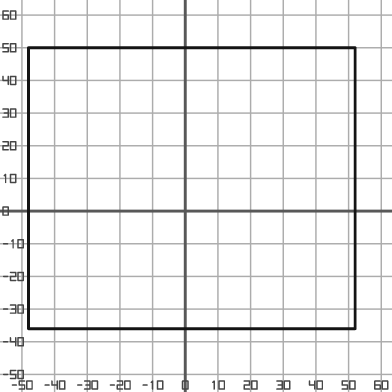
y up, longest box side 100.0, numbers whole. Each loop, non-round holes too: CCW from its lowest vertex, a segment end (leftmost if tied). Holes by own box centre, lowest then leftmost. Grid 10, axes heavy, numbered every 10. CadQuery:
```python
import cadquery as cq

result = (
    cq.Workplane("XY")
    .moveTo(-48.0, -36.0)
    .lineTo(52.0, -36.0)
    .lineTo(52.0, 50.0)
    .lineTo(-48.0, 50.0)
    .close()
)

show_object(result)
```